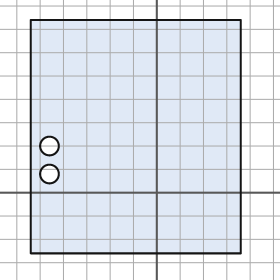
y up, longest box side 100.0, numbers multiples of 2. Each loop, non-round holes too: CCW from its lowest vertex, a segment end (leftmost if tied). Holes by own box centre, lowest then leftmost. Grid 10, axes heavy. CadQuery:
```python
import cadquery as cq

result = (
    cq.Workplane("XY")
    .moveTo(-54.0, -26.0)
    .lineTo(36.0, -26.0)
    .lineTo(36.0, 74.0)
    .lineTo(-54.0, 74.0)
    .close()
    .moveTo(-46.0, 8.0)
    .circle(4.0)
    .moveTo(-46.0, 20.0)
    .circle(4.0)
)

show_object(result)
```